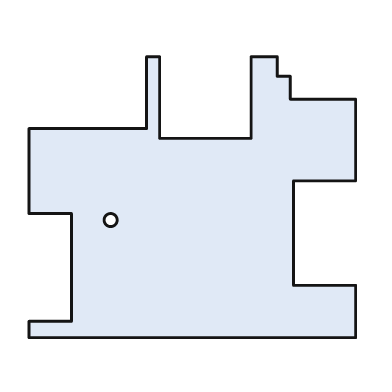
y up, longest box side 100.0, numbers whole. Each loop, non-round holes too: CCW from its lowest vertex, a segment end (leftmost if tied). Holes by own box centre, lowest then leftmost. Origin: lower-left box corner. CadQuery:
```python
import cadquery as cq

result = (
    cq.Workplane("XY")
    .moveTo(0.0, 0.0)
    .lineTo(100.0, 0.0)
    .lineTo(100.0, 16.0)
    .lineTo(81.0, 16.0)
    .lineTo(81.0, 48.0)
    .lineTo(100.0, 48.0)
    .lineTo(100.0, 73.0)
    .lineTo(80.0, 73.0)
    .lineTo(80.0, 80.0)
    .lineTo(76.0, 80.0)
    .lineTo(76.0, 86.0)
    .lineTo(68.0, 86.0)
    .lineTo(68.0, 61.0)
    .lineTo(40.0, 61.0)
    .lineTo(40.0, 86.0)
    .lineTo(36.0, 86.0)
    .lineTo(36.0, 64.0)
    .lineTo(0.0, 64.0)
    .lineTo(0.0, 38.0)
    .lineTo(13.0, 38.0)
    .lineTo(13.0, 5.0)
    .lineTo(0.0, 5.0)
    .close()
    .moveTo(25.0, 36.0)
    .circle(2.0)
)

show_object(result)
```